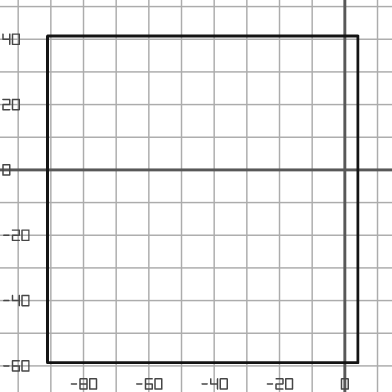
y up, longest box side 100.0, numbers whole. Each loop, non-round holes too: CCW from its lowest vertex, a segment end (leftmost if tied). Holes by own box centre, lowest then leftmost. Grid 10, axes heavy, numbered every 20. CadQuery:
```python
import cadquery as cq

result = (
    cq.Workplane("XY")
    .moveTo(-91.0, -59.0)
    .lineTo(4.0, -59.0)
    .lineTo(4.0, 41.0)
    .lineTo(-91.0, 41.0)
    .close()
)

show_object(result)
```